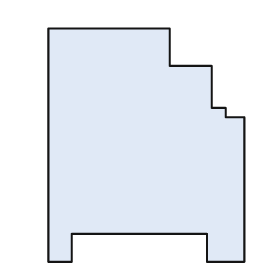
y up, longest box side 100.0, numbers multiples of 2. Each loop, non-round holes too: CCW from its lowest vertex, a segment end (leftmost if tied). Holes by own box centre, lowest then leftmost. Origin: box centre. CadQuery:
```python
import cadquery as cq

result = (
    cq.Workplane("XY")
    .moveTo(-42.0, -50.0)
    .lineTo(-32.0, -50.0)
    .lineTo(-32.0, -38.0)
    .lineTo(26.0, -38.0)
    .lineTo(26.0, -50.0)
    .lineTo(42.0, -50.0)
    .lineTo(42.0, 12.0)
    .lineTo(34.0, 12.0)
    .lineTo(34.0, 16.0)
    .lineTo(28.0, 16.0)
    .lineTo(28.0, 34.0)
    .lineTo(10.0, 34.0)
    .lineTo(10.0, 50.0)
    .lineTo(-42.0, 50.0)
    .close()
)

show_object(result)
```